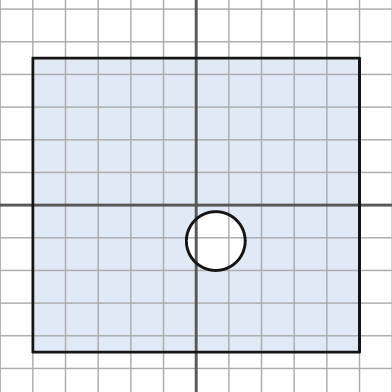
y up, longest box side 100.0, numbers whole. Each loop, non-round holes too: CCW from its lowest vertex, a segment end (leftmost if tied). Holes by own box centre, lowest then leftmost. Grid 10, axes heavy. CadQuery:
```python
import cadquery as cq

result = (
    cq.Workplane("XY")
    .moveTo(-50.0, -45.0)
    .lineTo(50.0, -45.0)
    .lineTo(50.0, 45.0)
    .lineTo(-50.0, 45.0)
    .close()
    .moveTo(6.0, -11.0)
    .circle(9.0)
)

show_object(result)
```